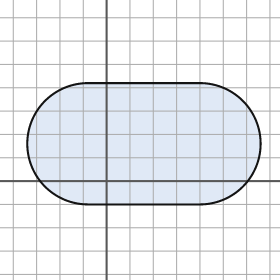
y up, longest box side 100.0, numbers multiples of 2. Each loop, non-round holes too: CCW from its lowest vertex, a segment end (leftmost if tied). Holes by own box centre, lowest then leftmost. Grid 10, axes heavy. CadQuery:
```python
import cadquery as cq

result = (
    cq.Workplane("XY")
    .moveTo(-8.0, -10.0)
    .lineTo(40.0, -10.0)
    .threePointArc((66.0, 16.0), (40.0, 42.0))
    .lineTo(-8.0, 42.0)
    .threePointArc((-34.0, 16.0), (-8.0, -10.0))
    .close()
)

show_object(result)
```